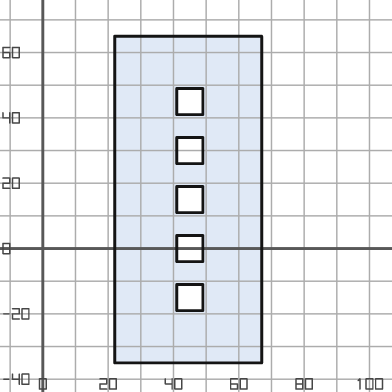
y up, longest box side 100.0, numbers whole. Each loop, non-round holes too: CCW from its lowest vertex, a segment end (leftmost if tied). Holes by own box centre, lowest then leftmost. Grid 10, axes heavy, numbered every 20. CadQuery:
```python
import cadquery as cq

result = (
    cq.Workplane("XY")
    .moveTo(22.0, -35.0)
    .lineTo(67.0, -35.0)
    .lineTo(67.0, 65.0)
    .lineTo(22.0, 65.0)
    .close()
    .moveTo(41.0, -19.0)
    .lineTo(49.0, -19.0)
    .lineTo(49.0, -11.0)
    .lineTo(41.0, -11.0)
    .close()
    .moveTo(41.0, -4.0)
    .lineTo(49.0, -4.0)
    .lineTo(49.0, 4.0)
    .lineTo(41.0, 4.0)
    .close()
    .moveTo(41.0, 11.0)
    .lineTo(49.0, 11.0)
    .lineTo(49.0, 19.0)
    .lineTo(41.0, 19.0)
    .close()
    .moveTo(41.0, 26.0)
    .lineTo(49.0, 26.0)
    .lineTo(49.0, 34.0)
    .lineTo(41.0, 34.0)
    .close()
    .moveTo(41.0, 41.0)
    .lineTo(49.0, 41.0)
    .lineTo(49.0, 49.0)
    .lineTo(41.0, 49.0)
    .close()
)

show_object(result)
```